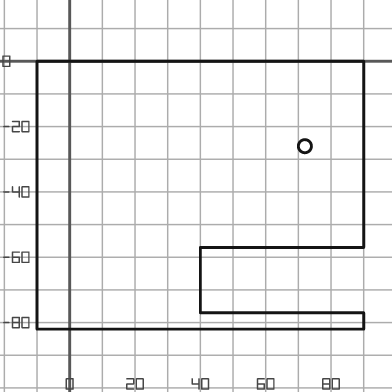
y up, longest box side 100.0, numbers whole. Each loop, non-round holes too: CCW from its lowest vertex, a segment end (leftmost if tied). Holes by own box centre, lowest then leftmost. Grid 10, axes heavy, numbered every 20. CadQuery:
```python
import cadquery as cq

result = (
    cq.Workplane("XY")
    .moveTo(-10.0, -82.0)
    .lineTo(90.0, -82.0)
    .lineTo(90.0, -77.0)
    .lineTo(40.0, -77.0)
    .lineTo(40.0, -57.0)
    .lineTo(90.0, -57.0)
    .lineTo(90.0, 0.0)
    .lineTo(-10.0, 0.0)
    .close()
    .moveTo(72.0, -26.0)
    .circle(2.0)
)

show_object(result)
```